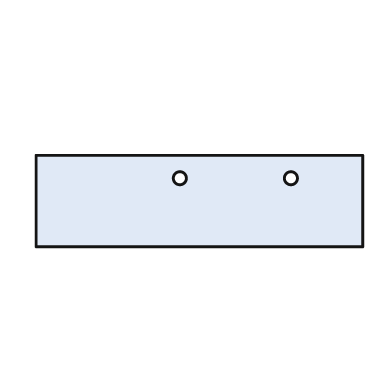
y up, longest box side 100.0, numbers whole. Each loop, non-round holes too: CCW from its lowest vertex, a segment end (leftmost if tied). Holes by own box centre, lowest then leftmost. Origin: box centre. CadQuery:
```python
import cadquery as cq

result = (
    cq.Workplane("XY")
    .moveTo(-50.0, -14.0)
    .lineTo(50.0, -14.0)
    .lineTo(50.0, 14.0)
    .lineTo(-50.0, 14.0)
    .close()
    .moveTo(-6.0, 7.0)
    .circle(2.0)
    .moveTo(28.0, 7.0)
    .circle(2.0)
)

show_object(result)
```